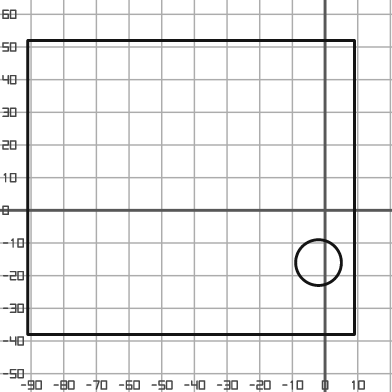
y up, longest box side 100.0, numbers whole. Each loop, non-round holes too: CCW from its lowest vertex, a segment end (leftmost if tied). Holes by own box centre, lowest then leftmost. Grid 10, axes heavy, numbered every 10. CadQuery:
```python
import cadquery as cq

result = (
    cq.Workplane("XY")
    .moveTo(-91.0, -38.0)
    .lineTo(9.0, -38.0)
    .lineTo(9.0, 52.0)
    .lineTo(-91.0, 52.0)
    .close()
    .moveTo(-2.0, -16.0)
    .circle(7.0)
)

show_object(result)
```